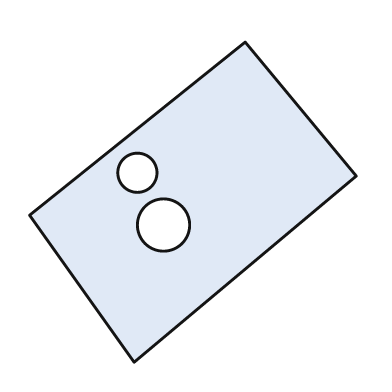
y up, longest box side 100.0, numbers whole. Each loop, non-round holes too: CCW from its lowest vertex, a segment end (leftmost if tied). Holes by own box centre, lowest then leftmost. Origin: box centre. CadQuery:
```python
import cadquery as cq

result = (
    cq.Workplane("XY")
    .moveTo(-18.0, -49.0)
    .lineTo(50.0, 8.0)
    .lineTo(16.0, 49.0)
    .lineTo(-50.0, -4.0)
    .close()
    .moveTo(-9.0, -7.0)
    .circle(8.0)
    .moveTo(-17.0, 9.0)
    .circle(6.0)
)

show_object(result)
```